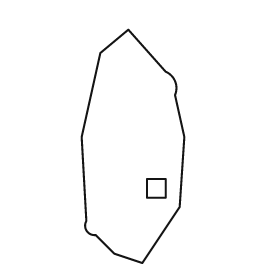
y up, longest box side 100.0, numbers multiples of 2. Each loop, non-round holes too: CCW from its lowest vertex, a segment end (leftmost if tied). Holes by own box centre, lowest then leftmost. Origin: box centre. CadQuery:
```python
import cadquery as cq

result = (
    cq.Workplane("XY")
    .moveTo(4.0, -50.0)
    .lineTo(20.0, -26.0)
    .lineTo(22.0, 4.0)
    .lineTo(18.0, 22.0)
    .threePointArc((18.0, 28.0), (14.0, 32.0))
    .lineTo(-2.0, 50.0)
    .lineTo(-14.0, 40.0)
    .lineTo(-22.0, 4.0)
    .lineTo(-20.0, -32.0)
    .threePointArc((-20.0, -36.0), (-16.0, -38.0))
    .lineTo(-8.0, -46.0)
    .close()
    .moveTo(6.0, -22.0)
    .lineTo(14.0, -22.0)
    .lineTo(14.0, -14.0)
    .lineTo(6.0, -14.0)
    .close()
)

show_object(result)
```